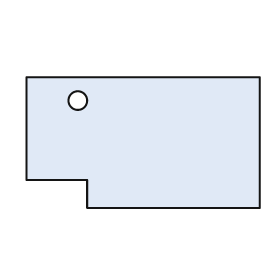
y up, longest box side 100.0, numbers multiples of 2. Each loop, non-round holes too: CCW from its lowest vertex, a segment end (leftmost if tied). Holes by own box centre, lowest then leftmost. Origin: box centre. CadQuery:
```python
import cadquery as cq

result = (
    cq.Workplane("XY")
    .moveTo(-24.0, -28.0)
    .lineTo(50.0, -28.0)
    .lineTo(50.0, 28.0)
    .lineTo(-50.0, 28.0)
    .lineTo(-50.0, -16.0)
    .lineTo(-24.0, -16.0)
    .close()
    .moveTo(-28.0, 18.0)
    .circle(4.0)
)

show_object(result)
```